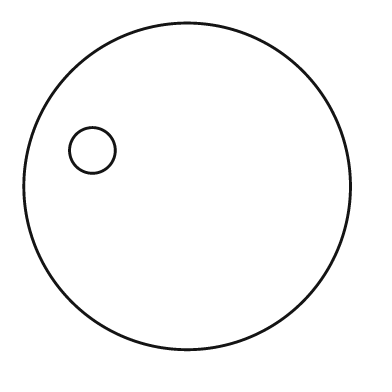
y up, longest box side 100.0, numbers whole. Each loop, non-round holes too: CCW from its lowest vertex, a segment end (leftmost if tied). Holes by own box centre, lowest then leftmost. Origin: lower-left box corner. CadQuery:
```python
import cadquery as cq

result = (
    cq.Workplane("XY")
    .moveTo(50.0, 50.0)
    .circle(50.0)
    .moveTo(21.0, 61.0)
    .circle(7.0)
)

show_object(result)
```